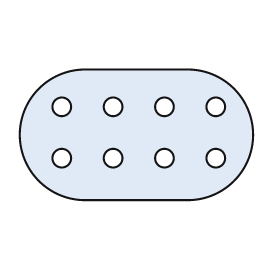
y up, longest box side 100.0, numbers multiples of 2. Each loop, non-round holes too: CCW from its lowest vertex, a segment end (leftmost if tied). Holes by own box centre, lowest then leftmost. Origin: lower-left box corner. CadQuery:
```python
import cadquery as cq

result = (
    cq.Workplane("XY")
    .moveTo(28.0, 0.0)
    .lineTo(72.0, 0.0)
    .threePointArc((100.0, 28.0), (72.0, 56.0))
    .lineTo(28.0, 56.0)
    .threePointArc((0.0, 28.0), (28.0, 0.0))
    .close()
    .moveTo(18.0, 18.0)
    .circle(4.0)
    .moveTo(40.0, 18.0)
    .circle(4.0)
    .moveTo(62.0, 18.0)
    .circle(4.0)
    .moveTo(84.0, 18.0)
    .circle(4.0)
    .moveTo(18.0, 40.0)
    .circle(4.0)
    .moveTo(40.0, 40.0)
    .circle(4.0)
    .moveTo(62.0, 40.0)
    .circle(4.0)
    .moveTo(84.0, 40.0)
    .circle(4.0)
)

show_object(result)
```